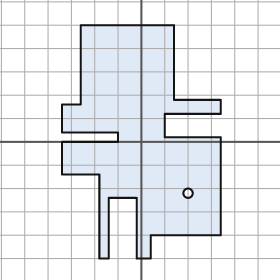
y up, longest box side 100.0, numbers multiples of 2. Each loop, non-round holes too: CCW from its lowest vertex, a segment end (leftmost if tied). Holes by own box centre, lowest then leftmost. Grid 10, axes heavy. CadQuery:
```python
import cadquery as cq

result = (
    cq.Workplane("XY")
    .moveTo(-18.0, -50.0)
    .lineTo(-14.0, -50.0)
    .lineTo(-14.0, -24.0)
    .lineTo(-2.0, -24.0)
    .lineTo(-2.0, -50.0)
    .lineTo(4.0, -50.0)
    .lineTo(4.0, -40.0)
    .lineTo(34.0, -40.0)
    .lineTo(34.0, 2.0)
    .lineTo(10.0, 2.0)
    .lineTo(10.0, 12.0)
    .lineTo(34.0, 12.0)
    .lineTo(34.0, 18.0)
    .lineTo(14.0, 18.0)
    .lineTo(14.0, 50.0)
    .lineTo(-26.0, 50.0)
    .lineTo(-26.0, 16.0)
    .lineTo(-34.0, 16.0)
    .lineTo(-34.0, 4.0)
    .lineTo(-10.0, 4.0)
    .lineTo(-10.0, 0.0)
    .lineTo(-34.0, 0.0)
    .lineTo(-34.0, -14.0)
    .lineTo(-18.0, -14.0)
    .close()
    .moveTo(20.0, -22.0)
    .circle(2.0)
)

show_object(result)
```